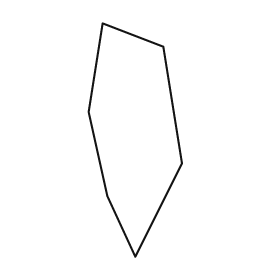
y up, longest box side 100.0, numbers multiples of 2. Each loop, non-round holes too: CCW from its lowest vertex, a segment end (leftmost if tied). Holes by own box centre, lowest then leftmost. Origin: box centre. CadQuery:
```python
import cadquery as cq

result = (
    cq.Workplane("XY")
    .moveTo(0.0, -50.0)
    .lineTo(20.0, -10.0)
    .lineTo(12.0, 40.0)
    .lineTo(-14.0, 50.0)
    .lineTo(-20.0, 12.0)
    .lineTo(-12.0, -24.0)
    .close()
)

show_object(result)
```